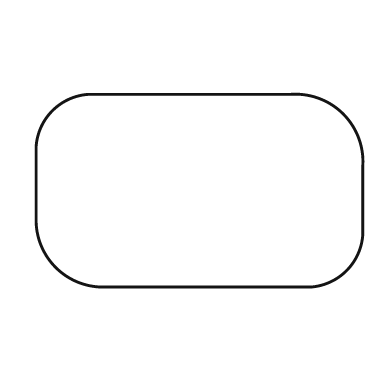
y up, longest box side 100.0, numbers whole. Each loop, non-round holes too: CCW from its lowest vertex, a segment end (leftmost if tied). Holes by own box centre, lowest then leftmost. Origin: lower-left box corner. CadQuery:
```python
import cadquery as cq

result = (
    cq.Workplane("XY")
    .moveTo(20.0, 0.0)
    .lineTo(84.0, 0.0)
    .threePointArc((95.0, 5.0), (100.0, 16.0))
    .lineTo(100.0, 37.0)
    .threePointArc((94.0, 53.0), (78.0, 59.0))
    .lineTo(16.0, 59.0)
    .threePointArc((5.0, 54.0), (0.0, 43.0))
    .lineTo(0.0, 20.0)
    .threePointArc((6.0, 6.0), (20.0, 0.0))
    .close()
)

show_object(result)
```